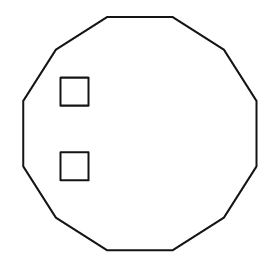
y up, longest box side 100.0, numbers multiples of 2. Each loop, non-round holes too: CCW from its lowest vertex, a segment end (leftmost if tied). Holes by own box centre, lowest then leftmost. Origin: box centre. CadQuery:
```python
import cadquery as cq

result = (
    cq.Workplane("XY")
    .moveTo(-14.0, -50.0)
    .lineTo(14.0, -50.0)
    .lineTo(36.0, -36.0)
    .lineTo(50.0, -14.0)
    .lineTo(50.0, 14.0)
    .lineTo(36.0, 36.0)
    .lineTo(14.0, 50.0)
    .lineTo(-14.0, 50.0)
    .lineTo(-36.0, 36.0)
    .lineTo(-50.0, 14.0)
    .lineTo(-50.0, -14.0)
    .lineTo(-36.0, -36.0)
    .close()
    .moveTo(-34.0, -20.0)
    .lineTo(-22.0, -20.0)
    .lineTo(-22.0, -8.0)
    .lineTo(-34.0, -8.0)
    .close()
    .moveTo(-34.0, 12.0)
    .lineTo(-22.0, 12.0)
    .lineTo(-22.0, 24.0)
    .lineTo(-34.0, 24.0)
    .close()
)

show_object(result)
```